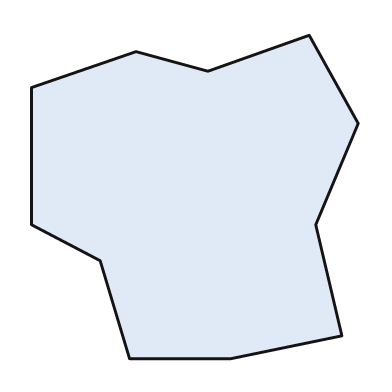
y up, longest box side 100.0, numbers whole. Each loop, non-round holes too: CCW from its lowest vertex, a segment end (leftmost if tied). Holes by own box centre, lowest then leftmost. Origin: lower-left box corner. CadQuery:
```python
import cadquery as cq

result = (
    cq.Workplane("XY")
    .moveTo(30.0, 0.0)
    .lineTo(61.0, 0.0)
    .lineTo(95.0, 7.0)
    .lineTo(87.0, 41.0)
    .lineTo(100.0, 72.0)
    .lineTo(85.0, 99.0)
    .lineTo(54.0, 88.0)
    .lineTo(32.0, 94.0)
    .lineTo(0.0, 83.0)
    .lineTo(0.0, 41.0)
    .lineTo(21.0, 30.0)
    .close()
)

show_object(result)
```